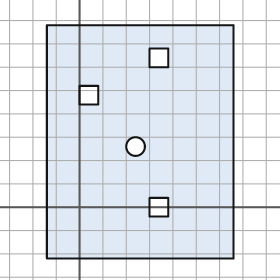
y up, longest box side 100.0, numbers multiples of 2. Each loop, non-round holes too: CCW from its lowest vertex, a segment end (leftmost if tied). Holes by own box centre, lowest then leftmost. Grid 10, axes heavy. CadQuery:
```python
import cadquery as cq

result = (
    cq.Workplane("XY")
    .moveTo(-14.0, -22.0)
    .lineTo(66.0, -22.0)
    .lineTo(66.0, 78.0)
    .lineTo(-14.0, 78.0)
    .close()
    .moveTo(30.0, -4.0)
    .lineTo(38.0, -4.0)
    .lineTo(38.0, 4.0)
    .lineTo(30.0, 4.0)
    .close()
    .moveTo(24.0, 26.0)
    .circle(4.0)
    .moveTo(0.0, 44.0)
    .lineTo(8.0, 44.0)
    .lineTo(8.0, 52.0)
    .lineTo(0.0, 52.0)
    .close()
    .moveTo(30.0, 60.0)
    .lineTo(38.0, 60.0)
    .lineTo(38.0, 68.0)
    .lineTo(30.0, 68.0)
    .close()
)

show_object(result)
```